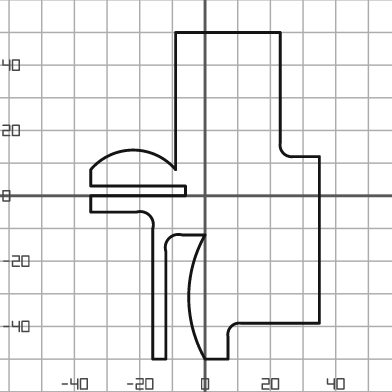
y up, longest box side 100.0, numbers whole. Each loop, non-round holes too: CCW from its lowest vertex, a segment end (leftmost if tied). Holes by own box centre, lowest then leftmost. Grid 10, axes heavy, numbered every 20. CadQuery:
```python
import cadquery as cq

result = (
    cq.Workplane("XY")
    .moveTo(-16.0, -50.0)
    .lineTo(-12.0, -50.0)
    .lineTo(-12.0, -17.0)
    .threePointArc((-11.0, -13.0), (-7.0, -12.0))
    .lineTo(0.0, -12.0)
    .threePointArc((-5.0, -31.0), (0.0, -50.0))
    .lineTo(7.0, -50.0)
    .lineTo(7.0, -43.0)
    .threePointArc((8.0, -40.0), (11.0, -39.0))
    .lineTo(35.0, -39.0)
    .lineTo(35.0, 12.0)
    .lineTo(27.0, 12.0)
    .threePointArc((24.0, 13.0), (23.0, 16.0))
    .lineTo(23.0, 50.0)
    .lineTo(-9.0, 50.0)
    .lineTo(-9.0, 8.0)
    .threePointArc((-22.0, 14.0), (-35.0, 8.0))
    .lineTo(-35.0, 3.0)
    .lineTo(-6.0, 3.0)
    .lineTo(-6.0, 0.0)
    .lineTo(-35.0, 0.0)
    .lineTo(-35.0, -5.0)
    .lineTo(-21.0, -5.0)
    .threePointArc((-17.0, -6.0), (-16.0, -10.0))
    .close()
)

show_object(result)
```